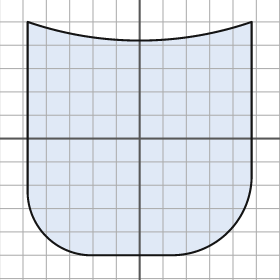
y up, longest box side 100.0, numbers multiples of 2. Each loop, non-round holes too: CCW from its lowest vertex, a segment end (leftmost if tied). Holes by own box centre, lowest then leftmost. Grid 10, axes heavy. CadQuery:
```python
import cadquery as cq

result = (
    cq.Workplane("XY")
    .moveTo(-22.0, -50.0)
    .lineTo(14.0, -50.0)
    .threePointArc((38.0, -40.0), (48.0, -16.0))
    .lineTo(48.0, 50.0)
    .threePointArc((0.0, 42.0), (-48.0, 50.0))
    .lineTo(-48.0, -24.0)
    .threePointArc((-40.0, -42.0), (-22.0, -50.0))
    .close()
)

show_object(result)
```